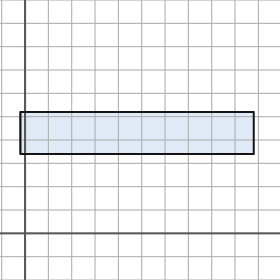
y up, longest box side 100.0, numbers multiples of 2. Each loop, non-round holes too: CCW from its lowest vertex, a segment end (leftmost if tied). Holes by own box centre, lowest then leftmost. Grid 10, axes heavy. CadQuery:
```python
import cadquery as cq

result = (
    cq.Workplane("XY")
    .moveTo(-2.0, 34.0)
    .lineTo(98.0, 34.0)
    .lineTo(98.0, 52.0)
    .lineTo(-2.0, 52.0)
    .close()
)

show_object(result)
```